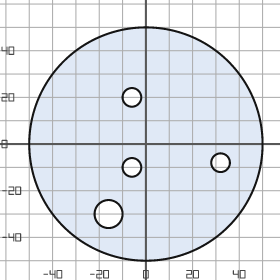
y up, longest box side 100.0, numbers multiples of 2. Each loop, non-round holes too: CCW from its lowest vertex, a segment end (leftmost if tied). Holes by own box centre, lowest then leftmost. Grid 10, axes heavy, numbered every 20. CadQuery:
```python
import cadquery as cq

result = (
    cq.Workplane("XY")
    .moveTo(0.0, 0.0)
    .circle(50.0)
    .moveTo(-16.0, -30.0)
    .circle(6.0)
    .moveTo(-6.0, -10.0)
    .circle(4.0)
    .moveTo(32.0, -8.0)
    .circle(4.0)
    .moveTo(-6.0, 20.0)
    .circle(4.0)
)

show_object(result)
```